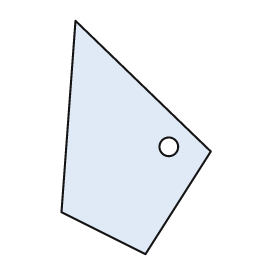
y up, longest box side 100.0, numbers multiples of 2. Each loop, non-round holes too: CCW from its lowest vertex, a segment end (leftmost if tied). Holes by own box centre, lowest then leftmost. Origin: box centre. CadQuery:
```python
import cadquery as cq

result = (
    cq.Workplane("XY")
    .moveTo(4.0, -50.0)
    .lineTo(32.0, -6.0)
    .lineTo(-26.0, 50.0)
    .lineTo(-32.0, -32.0)
    .close()
    .moveTo(14.0, -4.0)
    .circle(4.0)
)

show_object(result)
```